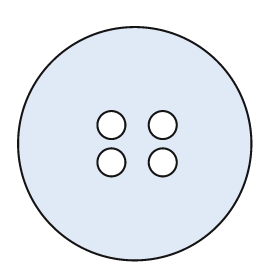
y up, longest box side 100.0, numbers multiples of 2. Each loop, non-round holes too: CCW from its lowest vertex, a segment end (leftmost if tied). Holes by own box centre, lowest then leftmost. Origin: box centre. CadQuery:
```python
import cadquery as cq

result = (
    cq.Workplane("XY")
    .moveTo(0.0, 0.0)
    .circle(50.0)
    .moveTo(-10.0, -8.0)
    .circle(6.0)
    .moveTo(12.0, -8.0)
    .circle(6.0)
    .moveTo(-10.0, 8.0)
    .circle(6.0)
    .moveTo(12.0, 8.0)
    .circle(6.0)
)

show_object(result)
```